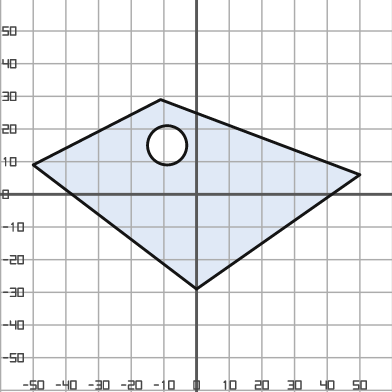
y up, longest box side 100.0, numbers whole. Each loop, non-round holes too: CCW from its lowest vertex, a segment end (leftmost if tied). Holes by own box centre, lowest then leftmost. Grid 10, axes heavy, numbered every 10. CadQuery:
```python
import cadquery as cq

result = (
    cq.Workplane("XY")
    .moveTo(0.0, -29.0)
    .lineTo(50.0, 6.0)
    .lineTo(-11.0, 29.0)
    .lineTo(-50.0, 9.0)
    .close()
    .moveTo(-9.0, 15.0)
    .circle(6.0)
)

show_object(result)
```